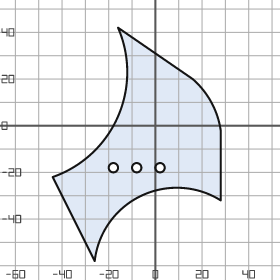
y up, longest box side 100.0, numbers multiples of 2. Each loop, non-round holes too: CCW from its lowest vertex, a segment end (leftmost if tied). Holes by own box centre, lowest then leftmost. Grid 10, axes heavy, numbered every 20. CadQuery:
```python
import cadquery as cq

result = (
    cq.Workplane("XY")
    .moveTo(-26.0, -58.0)
    .threePointArc((-6.0, -30.0), (28.0, -32.0))
    .lineTo(28.0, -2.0)
    .threePointArc((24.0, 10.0), (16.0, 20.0))
    .lineTo(-16.0, 42.0)
    .threePointArc((-16.0, 4.0), (-44.0, -22.0))
    .close()
    .moveTo(-18.0, -18.0)
    .circle(2.0)
    .moveTo(-8.0, -18.0)
    .circle(2.0)
    .moveTo(2.0, -18.0)
    .circle(2.0)
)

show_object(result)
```